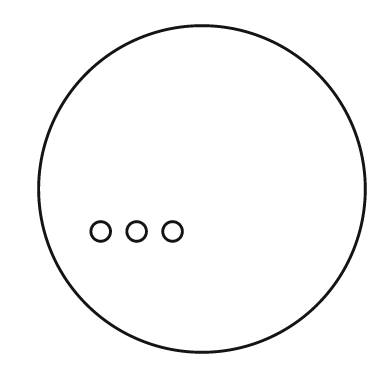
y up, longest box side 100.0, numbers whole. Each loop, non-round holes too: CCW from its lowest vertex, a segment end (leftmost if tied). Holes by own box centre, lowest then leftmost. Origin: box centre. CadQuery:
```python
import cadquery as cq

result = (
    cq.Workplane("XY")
    .moveTo(0.0, 0.0)
    .circle(50.0)
    .moveTo(-31.0, -13.0)
    .circle(3.0)
    .moveTo(-20.0, -13.0)
    .circle(3.0)
    .moveTo(-9.0, -13.0)
    .circle(3.0)
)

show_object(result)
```